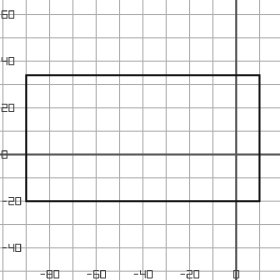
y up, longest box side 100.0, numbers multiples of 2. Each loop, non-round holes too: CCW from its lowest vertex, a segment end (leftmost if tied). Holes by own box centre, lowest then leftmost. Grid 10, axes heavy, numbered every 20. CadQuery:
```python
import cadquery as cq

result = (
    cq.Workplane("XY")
    .moveTo(-90.0, -20.0)
    .lineTo(10.0, -20.0)
    .lineTo(10.0, 34.0)
    .lineTo(-90.0, 34.0)
    .close()
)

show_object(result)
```